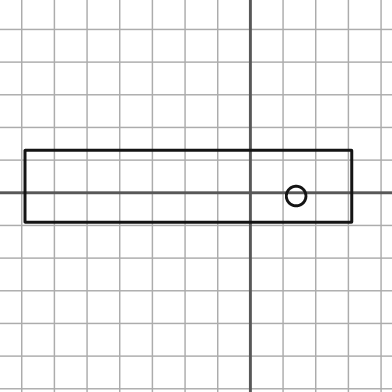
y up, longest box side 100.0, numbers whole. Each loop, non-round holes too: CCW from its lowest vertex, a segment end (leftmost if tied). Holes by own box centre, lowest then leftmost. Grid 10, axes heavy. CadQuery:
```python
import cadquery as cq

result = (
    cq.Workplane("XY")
    .moveTo(-69.0, -9.0)
    .lineTo(31.0, -9.0)
    .lineTo(31.0, 13.0)
    .lineTo(-69.0, 13.0)
    .close()
    .moveTo(14.0, -1.0)
    .circle(3.0)
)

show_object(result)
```